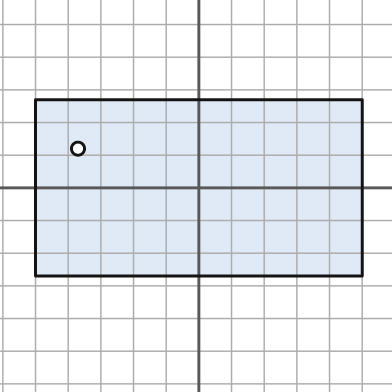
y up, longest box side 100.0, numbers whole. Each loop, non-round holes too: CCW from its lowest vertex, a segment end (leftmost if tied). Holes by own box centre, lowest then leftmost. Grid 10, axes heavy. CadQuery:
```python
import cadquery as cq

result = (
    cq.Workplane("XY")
    .moveTo(-50.0, -27.0)
    .lineTo(50.0, -27.0)
    .lineTo(50.0, 27.0)
    .lineTo(-50.0, 27.0)
    .close()
    .moveTo(-37.0, 12.0)
    .circle(2.0)
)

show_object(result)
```